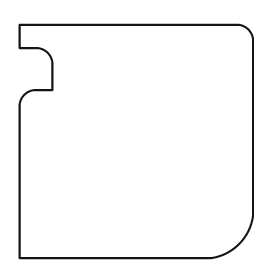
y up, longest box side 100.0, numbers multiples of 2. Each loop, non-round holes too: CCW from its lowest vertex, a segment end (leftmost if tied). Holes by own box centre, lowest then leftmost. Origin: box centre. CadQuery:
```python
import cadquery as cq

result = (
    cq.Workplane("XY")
    .moveTo(-50.0, -50.0)
    .lineTo(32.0, -50.0)
    .threePointArc((44.0, -44.0), (50.0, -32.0))
    .lineTo(50.0, 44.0)
    .threePointArc((48.0, 48.0), (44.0, 50.0))
    .lineTo(-50.0, 50.0)
    .lineTo(-50.0, 40.0)
    .lineTo(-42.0, 40.0)
    .threePointArc((-38.0, 38.0), (-36.0, 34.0))
    .lineTo(-36.0, 22.0)
    .lineTo(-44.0, 22.0)
    .threePointArc((-48.0, 20.0), (-50.0, 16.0))
    .close()
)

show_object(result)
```